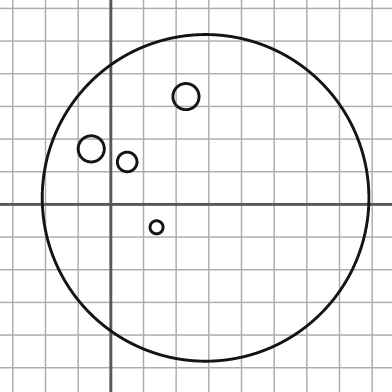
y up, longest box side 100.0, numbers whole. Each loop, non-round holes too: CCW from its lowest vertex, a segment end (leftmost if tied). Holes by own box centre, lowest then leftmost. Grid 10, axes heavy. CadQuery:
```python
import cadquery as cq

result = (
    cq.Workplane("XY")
    .moveTo(29.0, 2.0)
    .circle(50.0)
    .moveTo(14.0, -7.0)
    .circle(2.0)
    .moveTo(5.0, 13.0)
    .circle(3.0)
    .moveTo(-6.0, 17.0)
    .circle(4.0)
    .moveTo(23.0, 33.0)
    .circle(4.0)
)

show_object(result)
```